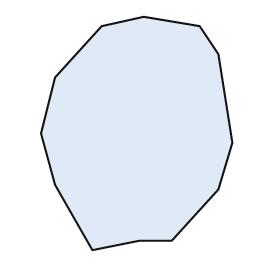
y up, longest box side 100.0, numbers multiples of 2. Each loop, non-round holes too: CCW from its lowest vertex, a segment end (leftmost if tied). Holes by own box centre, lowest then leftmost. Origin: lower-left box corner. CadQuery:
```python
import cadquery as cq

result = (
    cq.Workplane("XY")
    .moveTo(22.0, 0.0)
    .lineTo(42.0, 4.0)
    .lineTo(56.0, 4.0)
    .lineTo(76.0, 26.0)
    .lineTo(82.0, 46.0)
    .lineTo(76.0, 84.0)
    .lineTo(68.0, 96.0)
    .lineTo(44.0, 100.0)
    .lineTo(26.0, 96.0)
    .lineTo(6.0, 74.0)
    .lineTo(0.0, 50.0)
    .lineTo(6.0, 28.0)
    .close()
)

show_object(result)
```